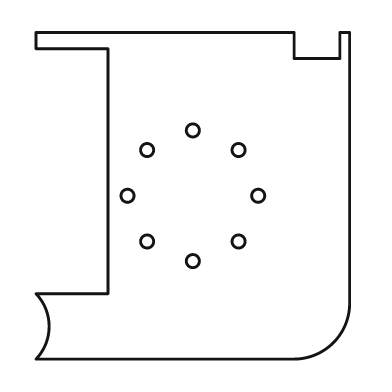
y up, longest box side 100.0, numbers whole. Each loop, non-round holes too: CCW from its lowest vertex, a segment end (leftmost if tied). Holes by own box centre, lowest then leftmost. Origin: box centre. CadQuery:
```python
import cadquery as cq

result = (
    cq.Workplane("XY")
    .moveTo(-48.0, -50.0)
    .lineTo(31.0, -50.0)
    .threePointArc((43.0, -45.0), (48.0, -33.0))
    .lineTo(48.0, 50.0)
    .lineTo(45.0, 50.0)
    .lineTo(45.0, 42.0)
    .lineTo(31.0, 42.0)
    .lineTo(31.0, 50.0)
    .lineTo(-48.0, 50.0)
    .lineTo(-48.0, 45.0)
    .lineTo(-26.0, 45.0)
    .lineTo(-26.0, -30.0)
    .lineTo(-48.0, -30.0)
    .threePointArc((-44.0, -40.0), (-48.0, -50.0))
    .close()
    .moveTo(0.0, -20.0)
    .circle(2.0)
    .moveTo(-14.0, -14.0)
    .circle(2.0)
    .moveTo(14.0, -14.0)
    .circle(2.0)
    .moveTo(-20.0, 0.0)
    .circle(2.0)
    .moveTo(20.0, 0.0)
    .circle(2.0)
    .moveTo(-14.0, 14.0)
    .circle(2.0)
    .moveTo(14.0, 14.0)
    .circle(2.0)
    .moveTo(0.0, 20.0)
    .circle(2.0)
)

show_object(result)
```